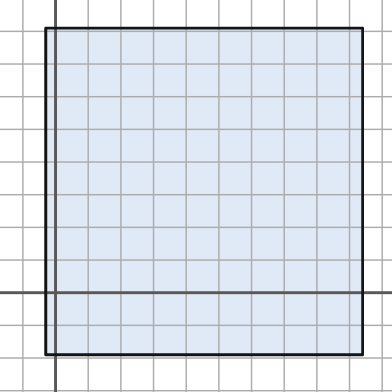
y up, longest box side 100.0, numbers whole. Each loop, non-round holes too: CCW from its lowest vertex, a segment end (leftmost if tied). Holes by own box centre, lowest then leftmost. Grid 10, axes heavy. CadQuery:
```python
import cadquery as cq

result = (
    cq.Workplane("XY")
    .moveTo(-3.0, -19.0)
    .lineTo(94.0, -19.0)
    .lineTo(94.0, 81.0)
    .lineTo(-3.0, 81.0)
    .close()
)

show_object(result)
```